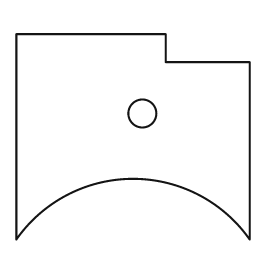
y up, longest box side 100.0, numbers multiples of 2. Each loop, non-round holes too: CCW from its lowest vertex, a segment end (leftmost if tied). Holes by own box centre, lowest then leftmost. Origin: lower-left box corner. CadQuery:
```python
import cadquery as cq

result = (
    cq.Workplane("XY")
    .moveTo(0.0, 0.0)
    .threePointArc((50.0, 26.0), (100.0, 0.0))
    .lineTo(100.0, 76.0)
    .lineTo(64.0, 76.0)
    .lineTo(64.0, 88.0)
    .lineTo(0.0, 88.0)
    .close()
    .moveTo(54.0, 54.0)
    .circle(6.0)
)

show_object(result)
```